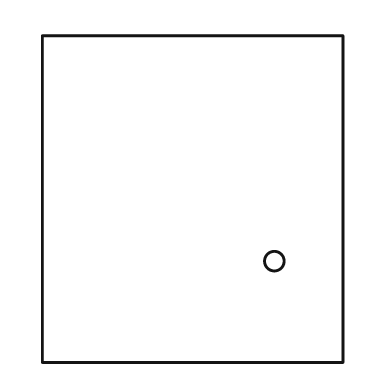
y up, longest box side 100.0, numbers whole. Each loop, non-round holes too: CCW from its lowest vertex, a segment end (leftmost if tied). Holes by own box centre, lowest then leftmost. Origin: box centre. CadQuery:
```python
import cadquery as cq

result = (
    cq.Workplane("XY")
    .moveTo(-46.0, -50.0)
    .lineTo(46.0, -50.0)
    .lineTo(46.0, 50.0)
    .lineTo(-46.0, 50.0)
    .close()
    .moveTo(25.0, -19.0)
    .circle(3.0)
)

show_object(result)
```